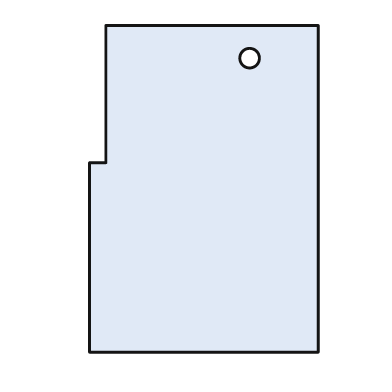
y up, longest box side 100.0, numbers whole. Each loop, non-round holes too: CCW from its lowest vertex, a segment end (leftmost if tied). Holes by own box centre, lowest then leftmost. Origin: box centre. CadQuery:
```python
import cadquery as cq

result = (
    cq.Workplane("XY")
    .moveTo(-35.0, -50.0)
    .lineTo(35.0, -50.0)
    .lineTo(35.0, 50.0)
    .lineTo(-30.0, 50.0)
    .lineTo(-30.0, 8.0)
    .lineTo(-35.0, 8.0)
    .close()
    .moveTo(14.0, 40.0)
    .circle(3.0)
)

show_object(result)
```